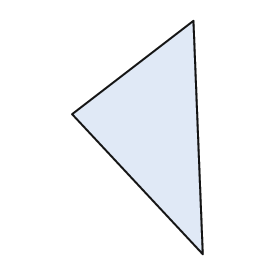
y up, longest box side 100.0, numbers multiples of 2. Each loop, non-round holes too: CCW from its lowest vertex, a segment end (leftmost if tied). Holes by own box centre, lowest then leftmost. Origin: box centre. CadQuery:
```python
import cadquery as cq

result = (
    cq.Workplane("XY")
    .moveTo(28.0, -50.0)
    .lineTo(24.0, 50.0)
    .lineTo(-28.0, 10.0)
    .close()
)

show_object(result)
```